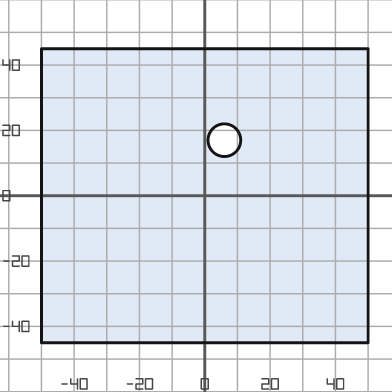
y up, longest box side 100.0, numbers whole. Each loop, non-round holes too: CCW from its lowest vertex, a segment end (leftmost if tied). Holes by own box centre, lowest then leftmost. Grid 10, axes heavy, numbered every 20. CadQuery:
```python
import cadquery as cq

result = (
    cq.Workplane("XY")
    .moveTo(-50.0, -45.0)
    .lineTo(50.0, -45.0)
    .lineTo(50.0, 45.0)
    .lineTo(-50.0, 45.0)
    .close()
    .moveTo(6.0, 17.0)
    .circle(5.0)
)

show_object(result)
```